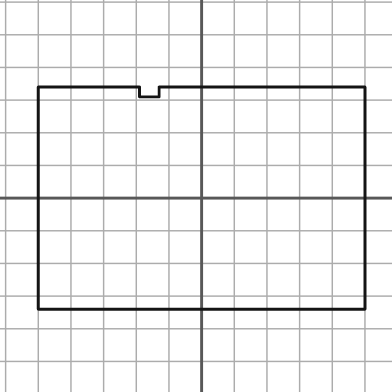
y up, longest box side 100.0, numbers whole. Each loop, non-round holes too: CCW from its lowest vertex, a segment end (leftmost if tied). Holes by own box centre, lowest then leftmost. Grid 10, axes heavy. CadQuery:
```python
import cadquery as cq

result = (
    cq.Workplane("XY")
    .moveTo(-50.0, -34.0)
    .lineTo(50.0, -34.0)
    .lineTo(50.0, 34.0)
    .lineTo(-13.0, 34.0)
    .lineTo(-13.0, 31.0)
    .lineTo(-19.0, 31.0)
    .lineTo(-19.0, 34.0)
    .lineTo(-50.0, 34.0)
    .close()
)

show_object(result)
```